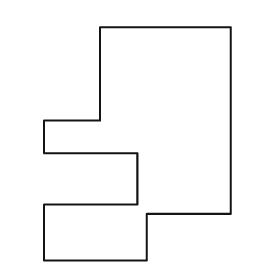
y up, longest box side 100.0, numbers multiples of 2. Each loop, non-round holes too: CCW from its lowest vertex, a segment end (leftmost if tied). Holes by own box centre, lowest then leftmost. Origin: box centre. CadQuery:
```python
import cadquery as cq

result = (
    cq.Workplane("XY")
    .moveTo(-40.0, -50.0)
    .lineTo(4.0, -50.0)
    .lineTo(4.0, -30.0)
    .lineTo(40.0, -30.0)
    .lineTo(40.0, 50.0)
    .lineTo(-16.0, 50.0)
    .lineTo(-16.0, 10.0)
    .lineTo(-40.0, 10.0)
    .lineTo(-40.0, -4.0)
    .lineTo(0.0, -4.0)
    .lineTo(0.0, -26.0)
    .lineTo(-40.0, -26.0)
    .close()
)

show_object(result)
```